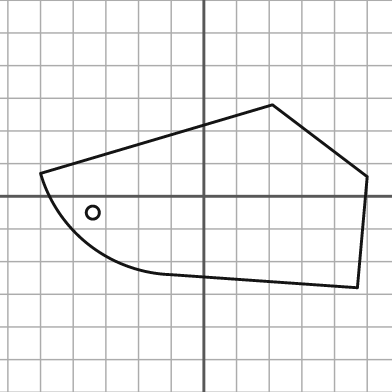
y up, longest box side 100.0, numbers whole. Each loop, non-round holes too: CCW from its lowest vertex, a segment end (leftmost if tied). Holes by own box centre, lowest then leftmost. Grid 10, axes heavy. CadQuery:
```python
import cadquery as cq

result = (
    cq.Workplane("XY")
    .moveTo(47.0, -28.0)
    .lineTo(50.0, 6.0)
    .lineTo(21.0, 28.0)
    .lineTo(-50.0, 7.0)
    .threePointArc((-35.0, -15.0), (-10.0, -24.0))
    .close()
    .moveTo(-34.0, -5.0)
    .circle(2.0)
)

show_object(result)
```